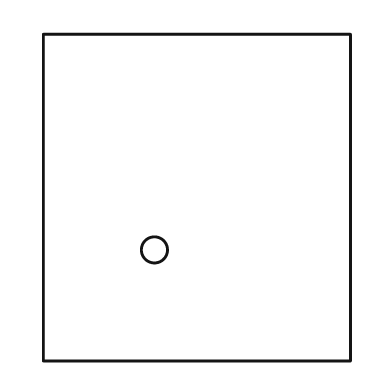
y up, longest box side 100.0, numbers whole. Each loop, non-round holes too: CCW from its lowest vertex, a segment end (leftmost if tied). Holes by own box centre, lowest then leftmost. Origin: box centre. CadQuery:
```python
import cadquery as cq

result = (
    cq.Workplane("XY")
    .moveTo(-47.0, -50.0)
    .lineTo(47.0, -50.0)
    .lineTo(47.0, 50.0)
    .lineTo(-47.0, 50.0)
    .close()
    .moveTo(-13.0, -16.0)
    .circle(4.0)
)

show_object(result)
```